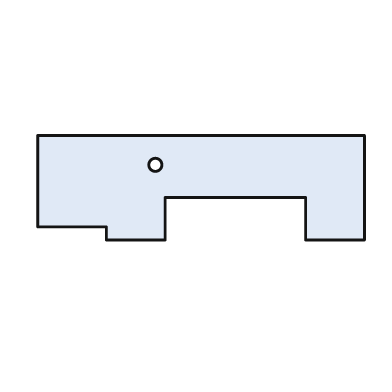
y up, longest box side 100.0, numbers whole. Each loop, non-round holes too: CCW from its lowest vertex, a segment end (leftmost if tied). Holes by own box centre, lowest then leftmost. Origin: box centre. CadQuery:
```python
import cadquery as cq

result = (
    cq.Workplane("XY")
    .moveTo(-29.0, -16.0)
    .lineTo(-11.0, -16.0)
    .lineTo(-11.0, -3.0)
    .lineTo(32.0, -3.0)
    .lineTo(32.0, -16.0)
    .lineTo(50.0, -16.0)
    .lineTo(50.0, 16.0)
    .lineTo(-50.0, 16.0)
    .lineTo(-50.0, -12.0)
    .lineTo(-29.0, -12.0)
    .close()
    .moveTo(-14.0, 7.0)
    .circle(2.0)
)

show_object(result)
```